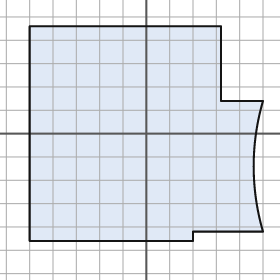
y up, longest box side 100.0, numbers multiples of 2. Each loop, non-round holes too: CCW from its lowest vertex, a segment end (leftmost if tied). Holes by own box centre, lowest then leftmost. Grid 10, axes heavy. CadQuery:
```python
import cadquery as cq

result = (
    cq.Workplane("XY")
    .moveTo(-50.0, -46.0)
    .lineTo(20.0, -46.0)
    .lineTo(20.0, -42.0)
    .lineTo(50.0, -42.0)
    .threePointArc((46.0, -14.0), (50.0, 14.0))
    .lineTo(32.0, 14.0)
    .lineTo(32.0, 46.0)
    .lineTo(-50.0, 46.0)
    .close()
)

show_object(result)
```